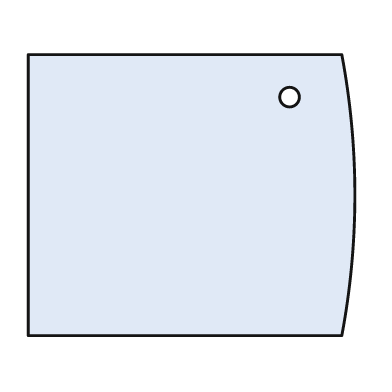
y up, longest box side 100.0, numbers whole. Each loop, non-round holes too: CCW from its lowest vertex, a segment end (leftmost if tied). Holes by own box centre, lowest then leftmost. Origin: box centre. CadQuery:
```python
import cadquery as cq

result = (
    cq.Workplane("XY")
    .moveTo(-50.0, -43.0)
    .lineTo(46.0, -43.0)
    .threePointArc((50.0, 0.0), (46.0, 43.0))
    .lineTo(-50.0, 43.0)
    .close()
    .moveTo(30.0, 30.0)
    .circle(3.0)
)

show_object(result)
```